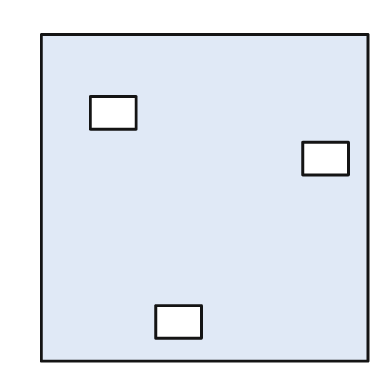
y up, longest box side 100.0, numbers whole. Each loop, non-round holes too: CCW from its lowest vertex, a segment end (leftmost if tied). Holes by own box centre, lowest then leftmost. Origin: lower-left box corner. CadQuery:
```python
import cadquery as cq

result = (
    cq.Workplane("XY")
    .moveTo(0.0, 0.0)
    .lineTo(100.0, 0.0)
    .lineTo(100.0, 100.0)
    .lineTo(0.0, 100.0)
    .close()
    .moveTo(35.0, 7.0)
    .lineTo(49.0, 7.0)
    .lineTo(49.0, 17.0)
    .lineTo(35.0, 17.0)
    .close()
    .moveTo(80.0, 57.0)
    .lineTo(94.0, 57.0)
    .lineTo(94.0, 67.0)
    .lineTo(80.0, 67.0)
    .close()
    .moveTo(15.0, 71.0)
    .lineTo(29.0, 71.0)
    .lineTo(29.0, 81.0)
    .lineTo(15.0, 81.0)
    .close()
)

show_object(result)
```